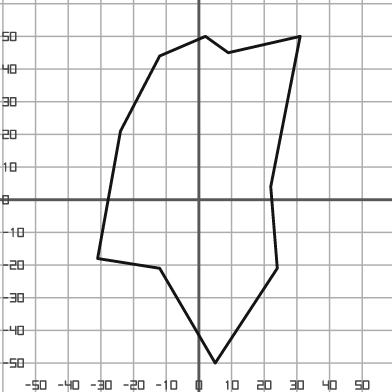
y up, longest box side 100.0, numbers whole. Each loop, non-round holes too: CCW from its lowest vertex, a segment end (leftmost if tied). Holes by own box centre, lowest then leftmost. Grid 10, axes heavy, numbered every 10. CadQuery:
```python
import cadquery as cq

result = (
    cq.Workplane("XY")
    .moveTo(5.0, -50.0)
    .lineTo(24.0, -21.0)
    .lineTo(22.0, 4.0)
    .lineTo(31.0, 50.0)
    .lineTo(9.0, 45.0)
    .lineTo(2.0, 50.0)
    .lineTo(-12.0, 44.0)
    .lineTo(-24.0, 21.0)
    .lineTo(-31.0, -18.0)
    .lineTo(-12.0, -21.0)
    .close()
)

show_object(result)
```